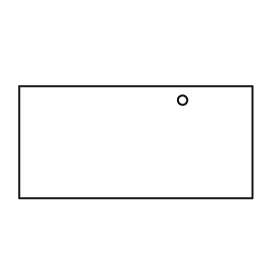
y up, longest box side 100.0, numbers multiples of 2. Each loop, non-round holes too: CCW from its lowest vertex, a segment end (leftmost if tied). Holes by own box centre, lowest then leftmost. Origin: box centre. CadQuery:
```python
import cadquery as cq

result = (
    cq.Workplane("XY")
    .moveTo(-50.0, -24.0)
    .lineTo(50.0, -24.0)
    .lineTo(50.0, 24.0)
    .lineTo(-50.0, 24.0)
    .close()
    .moveTo(20.0, 18.0)
    .circle(2.0)
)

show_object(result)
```